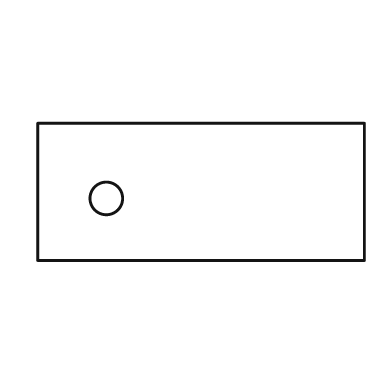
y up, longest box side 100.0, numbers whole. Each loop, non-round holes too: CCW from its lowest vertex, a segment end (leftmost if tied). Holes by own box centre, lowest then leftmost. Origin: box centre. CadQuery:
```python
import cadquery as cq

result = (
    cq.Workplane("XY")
    .moveTo(-50.0, -21.0)
    .lineTo(50.0, -21.0)
    .lineTo(50.0, 21.0)
    .lineTo(-50.0, 21.0)
    .close()
    .moveTo(-29.0, -2.0)
    .circle(5.0)
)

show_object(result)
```